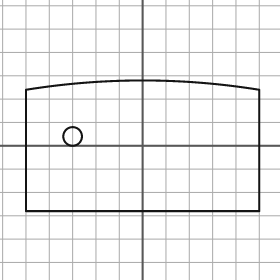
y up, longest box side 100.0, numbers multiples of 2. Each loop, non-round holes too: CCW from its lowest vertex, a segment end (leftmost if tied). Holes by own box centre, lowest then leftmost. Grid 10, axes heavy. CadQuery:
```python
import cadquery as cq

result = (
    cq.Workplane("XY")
    .moveTo(-50.0, -28.0)
    .lineTo(50.0, -28.0)
    .lineTo(50.0, 24.0)
    .threePointArc((0.0, 28.0), (-50.0, 24.0))
    .close()
    .moveTo(-30.0, 4.0)
    .circle(4.0)
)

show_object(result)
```